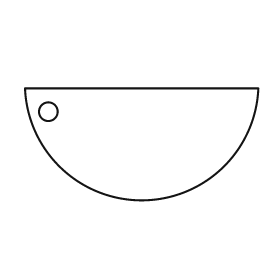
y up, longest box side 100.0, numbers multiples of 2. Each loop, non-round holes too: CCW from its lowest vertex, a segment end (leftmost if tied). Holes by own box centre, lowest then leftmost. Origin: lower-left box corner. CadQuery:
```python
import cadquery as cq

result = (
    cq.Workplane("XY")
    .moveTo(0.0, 48.0)
    .threePointArc((50.0, 0.0), (100.0, 48.0))
    .close()
    .moveTo(10.0, 38.0)
    .circle(4.0)
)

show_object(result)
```